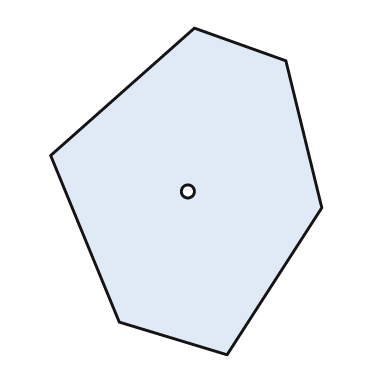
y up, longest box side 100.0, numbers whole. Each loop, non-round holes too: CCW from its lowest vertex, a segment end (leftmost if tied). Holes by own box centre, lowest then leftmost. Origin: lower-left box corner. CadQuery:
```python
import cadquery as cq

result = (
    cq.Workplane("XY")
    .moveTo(54.0, 0.0)
    .lineTo(83.0, 45.0)
    .lineTo(72.0, 90.0)
    .lineTo(44.0, 100.0)
    .lineTo(0.0, 61.0)
    .lineTo(21.0, 10.0)
    .close()
    .moveTo(42.0, 50.0)
    .circle(2.0)
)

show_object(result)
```